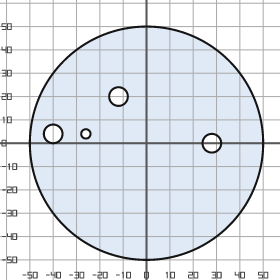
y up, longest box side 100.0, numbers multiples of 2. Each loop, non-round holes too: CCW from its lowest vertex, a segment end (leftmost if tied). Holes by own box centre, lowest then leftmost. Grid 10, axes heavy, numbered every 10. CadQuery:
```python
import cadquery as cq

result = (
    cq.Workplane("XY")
    .moveTo(0.0, 0.0)
    .circle(50.0)
    .moveTo(28.0, 0.0)
    .circle(4.0)
    .moveTo(-40.0, 4.0)
    .circle(4.0)
    .moveTo(-26.0, 4.0)
    .circle(2.0)
    .moveTo(-12.0, 20.0)
    .circle(4.0)
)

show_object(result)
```